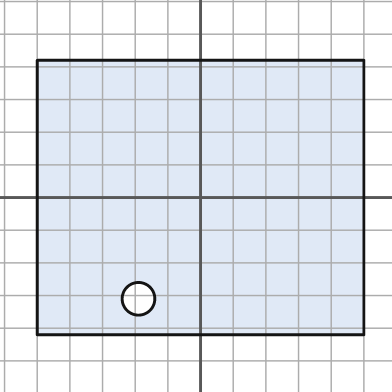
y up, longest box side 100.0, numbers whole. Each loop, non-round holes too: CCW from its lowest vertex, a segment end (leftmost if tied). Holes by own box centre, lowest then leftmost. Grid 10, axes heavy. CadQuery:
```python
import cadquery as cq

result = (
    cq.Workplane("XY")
    .moveTo(-50.0, -42.0)
    .lineTo(50.0, -42.0)
    .lineTo(50.0, 42.0)
    .lineTo(-50.0, 42.0)
    .close()
    .moveTo(-19.0, -31.0)
    .circle(5.0)
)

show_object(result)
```